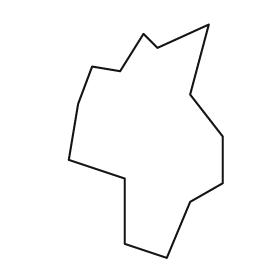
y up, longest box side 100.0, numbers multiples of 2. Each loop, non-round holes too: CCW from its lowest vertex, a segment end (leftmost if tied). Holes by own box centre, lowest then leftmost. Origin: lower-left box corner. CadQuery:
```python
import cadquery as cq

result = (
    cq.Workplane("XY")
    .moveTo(42.0, 0.0)
    .lineTo(52.0, 24.0)
    .lineTo(66.0, 32.0)
    .lineTo(66.0, 52.0)
    .lineTo(52.0, 70.0)
    .lineTo(60.0, 100.0)
    .lineTo(38.0, 90.0)
    .lineTo(32.0, 96.0)
    .lineTo(22.0, 80.0)
    .lineTo(10.0, 82.0)
    .lineTo(4.0, 66.0)
    .lineTo(0.0, 42.0)
    .lineTo(24.0, 34.0)
    .lineTo(24.0, 6.0)
    .close()
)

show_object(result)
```